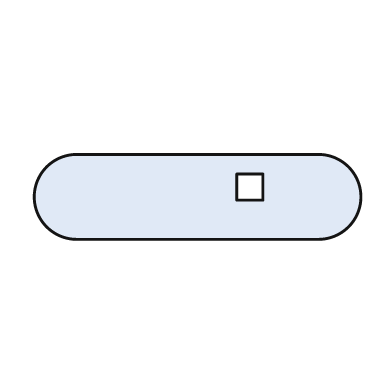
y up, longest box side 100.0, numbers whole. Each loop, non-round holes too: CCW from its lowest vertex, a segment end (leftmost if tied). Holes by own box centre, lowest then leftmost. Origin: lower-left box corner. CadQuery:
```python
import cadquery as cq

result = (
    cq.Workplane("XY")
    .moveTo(13.0, 0.0)
    .lineTo(87.0, 0.0)
    .threePointArc((100.0, 13.0), (87.0, 26.0))
    .lineTo(13.0, 26.0)
    .threePointArc((0.0, 13.0), (13.0, 0.0))
    .close()
    .moveTo(62.0, 12.0)
    .lineTo(70.0, 12.0)
    .lineTo(70.0, 20.0)
    .lineTo(62.0, 20.0)
    .close()
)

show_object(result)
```